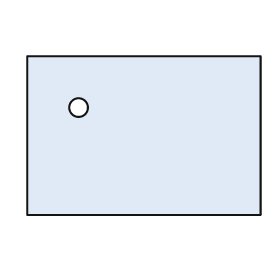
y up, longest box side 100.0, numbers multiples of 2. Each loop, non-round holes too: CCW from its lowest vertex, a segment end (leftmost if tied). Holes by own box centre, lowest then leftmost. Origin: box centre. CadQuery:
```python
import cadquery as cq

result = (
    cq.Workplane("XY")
    .moveTo(-50.0, -34.0)
    .lineTo(50.0, -34.0)
    .lineTo(50.0, 34.0)
    .lineTo(-50.0, 34.0)
    .close()
    .moveTo(-28.0, 12.0)
    .circle(4.0)
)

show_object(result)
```